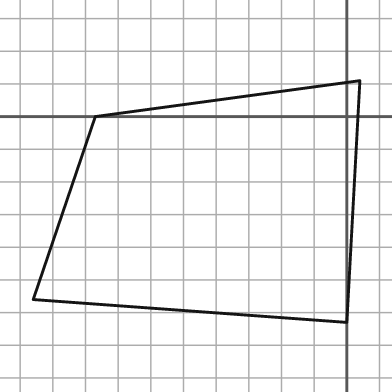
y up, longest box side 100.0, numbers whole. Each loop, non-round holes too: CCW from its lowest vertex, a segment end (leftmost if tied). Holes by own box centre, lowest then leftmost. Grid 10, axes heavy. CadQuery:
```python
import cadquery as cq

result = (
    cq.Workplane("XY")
    .moveTo(0.0, -63.0)
    .lineTo(4.0, 11.0)
    .lineTo(-77.0, 0.0)
    .lineTo(-96.0, -56.0)
    .close()
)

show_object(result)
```